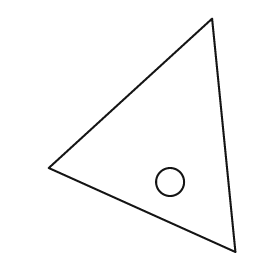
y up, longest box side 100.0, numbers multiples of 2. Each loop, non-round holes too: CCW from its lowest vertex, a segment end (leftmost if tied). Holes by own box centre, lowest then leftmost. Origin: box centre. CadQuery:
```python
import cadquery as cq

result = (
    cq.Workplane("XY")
    .moveTo(40.0, -50.0)
    .lineTo(30.0, 50.0)
    .lineTo(-40.0, -14.0)
    .close()
    .moveTo(12.0, -20.0)
    .circle(6.0)
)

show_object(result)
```